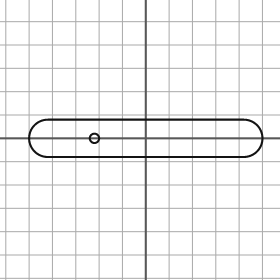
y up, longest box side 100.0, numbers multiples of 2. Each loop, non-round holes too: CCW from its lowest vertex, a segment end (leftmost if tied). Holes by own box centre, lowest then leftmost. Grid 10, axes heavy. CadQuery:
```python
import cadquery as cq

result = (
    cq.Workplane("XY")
    .moveTo(-42.0, -8.0)
    .lineTo(42.0, -8.0)
    .threePointArc((50.0, 0.0), (42.0, 8.0))
    .lineTo(-42.0, 8.0)
    .threePointArc((-50.0, 0.0), (-42.0, -8.0))
    .close()
    .moveTo(-22.0, 0.0)
    .circle(2.0)
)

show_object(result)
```